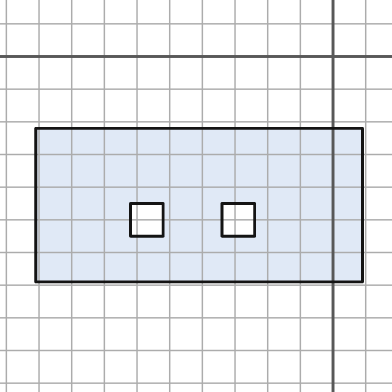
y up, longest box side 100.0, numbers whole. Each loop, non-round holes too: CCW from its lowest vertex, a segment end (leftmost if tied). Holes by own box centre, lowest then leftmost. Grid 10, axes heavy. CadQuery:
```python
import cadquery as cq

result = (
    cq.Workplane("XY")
    .moveTo(-91.0, -69.0)
    .lineTo(9.0, -69.0)
    .lineTo(9.0, -22.0)
    .lineTo(-91.0, -22.0)
    .close()
    .moveTo(-62.0, -55.0)
    .lineTo(-52.0, -55.0)
    .lineTo(-52.0, -45.0)
    .lineTo(-62.0, -45.0)
    .close()
    .moveTo(-34.0, -55.0)
    .lineTo(-24.0, -55.0)
    .lineTo(-24.0, -45.0)
    .lineTo(-34.0, -45.0)
    .close()
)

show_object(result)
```